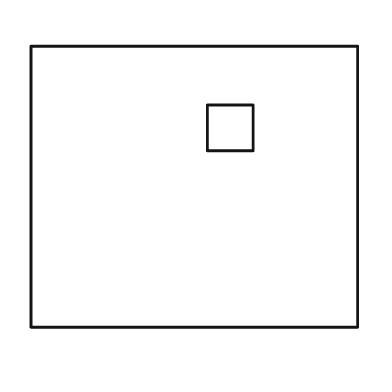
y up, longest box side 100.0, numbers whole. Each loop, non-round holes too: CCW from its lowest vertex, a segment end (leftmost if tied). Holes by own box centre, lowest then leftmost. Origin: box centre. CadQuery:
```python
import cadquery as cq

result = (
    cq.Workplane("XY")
    .moveTo(-50.0, -43.0)
    .lineTo(50.0, -43.0)
    .lineTo(50.0, 43.0)
    .lineTo(-50.0, 43.0)
    .close()
    .moveTo(4.0, 11.0)
    .lineTo(18.0, 11.0)
    .lineTo(18.0, 25.0)
    .lineTo(4.0, 25.0)
    .close()
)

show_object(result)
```